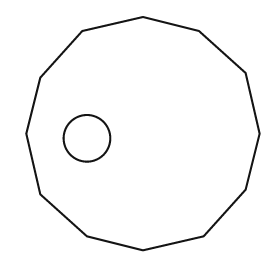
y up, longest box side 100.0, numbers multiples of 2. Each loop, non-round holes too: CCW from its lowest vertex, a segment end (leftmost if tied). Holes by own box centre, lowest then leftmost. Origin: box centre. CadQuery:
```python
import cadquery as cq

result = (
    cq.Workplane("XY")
    .moveTo(0.0, -50.0)
    .lineTo(26.0, -44.0)
    .lineTo(44.0, -24.0)
    .lineTo(50.0, 0.0)
    .lineTo(44.0, 26.0)
    .lineTo(24.0, 44.0)
    .lineTo(0.0, 50.0)
    .lineTo(-26.0, 44.0)
    .lineTo(-44.0, 24.0)
    .lineTo(-50.0, 0.0)
    .lineTo(-44.0, -26.0)
    .lineTo(-24.0, -44.0)
    .close()
    .moveTo(-24.0, -2.0)
    .circle(10.0)
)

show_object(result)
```